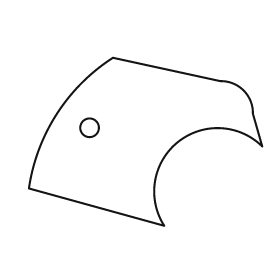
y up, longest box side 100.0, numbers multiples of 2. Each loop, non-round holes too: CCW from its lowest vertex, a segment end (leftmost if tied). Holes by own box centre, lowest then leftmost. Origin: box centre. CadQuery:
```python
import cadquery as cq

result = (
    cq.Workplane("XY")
    .moveTo(8.0, -36.0)
    .threePointArc((14.0, 0.0), (50.0, -2.0))
    .lineTo(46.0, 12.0)
    .threePointArc((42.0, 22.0), (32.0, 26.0))
    .lineTo(-14.0, 36.0)
    .threePointArc((-38.0, 12.0), (-50.0, -20.0))
    .close()
    .moveTo(-24.0, 6.0)
    .circle(4.0)
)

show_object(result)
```